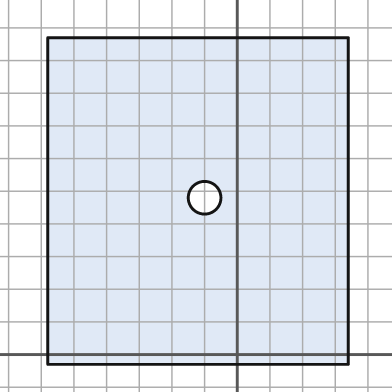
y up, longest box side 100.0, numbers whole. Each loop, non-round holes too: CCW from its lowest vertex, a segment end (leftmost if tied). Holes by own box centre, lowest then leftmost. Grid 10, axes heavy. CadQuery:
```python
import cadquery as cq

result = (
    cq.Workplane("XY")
    .moveTo(-58.0, -3.0)
    .lineTo(34.0, -3.0)
    .lineTo(34.0, 97.0)
    .lineTo(-58.0, 97.0)
    .close()
    .moveTo(-10.0, 48.0)
    .circle(5.0)
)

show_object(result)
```